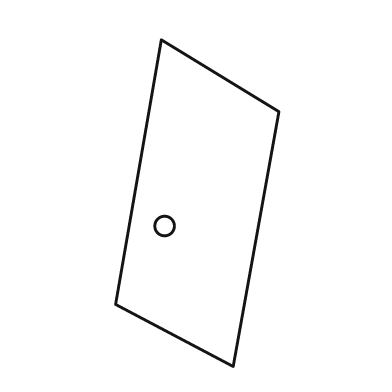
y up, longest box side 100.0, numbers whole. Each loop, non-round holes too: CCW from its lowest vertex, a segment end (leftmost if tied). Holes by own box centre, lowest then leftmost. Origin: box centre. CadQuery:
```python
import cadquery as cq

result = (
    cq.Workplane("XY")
    .moveTo(11.0, -50.0)
    .lineTo(25.0, 28.0)
    .lineTo(-11.0, 50.0)
    .lineTo(-25.0, -31.0)
    .close()
    .moveTo(-10.0, -7.0)
    .circle(3.0)
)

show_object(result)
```